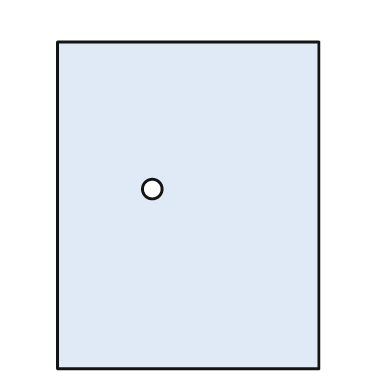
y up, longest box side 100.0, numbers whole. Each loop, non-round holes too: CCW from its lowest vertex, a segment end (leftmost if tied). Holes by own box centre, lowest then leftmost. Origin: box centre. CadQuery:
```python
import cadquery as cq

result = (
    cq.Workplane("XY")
    .moveTo(-40.0, -50.0)
    .lineTo(40.0, -50.0)
    .lineTo(40.0, 50.0)
    .lineTo(-40.0, 50.0)
    .close()
    .moveTo(-11.0, 5.0)
    .circle(3.0)
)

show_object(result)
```